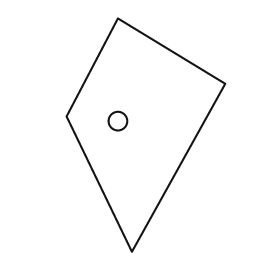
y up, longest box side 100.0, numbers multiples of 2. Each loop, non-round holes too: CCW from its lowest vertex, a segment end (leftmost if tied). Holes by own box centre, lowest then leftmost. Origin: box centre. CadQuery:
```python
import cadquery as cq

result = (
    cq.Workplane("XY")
    .moveTo(-6.0, -50.0)
    .lineTo(34.0, 22.0)
    .lineTo(-12.0, 50.0)
    .lineTo(-34.0, 8.0)
    .close()
    .moveTo(-12.0, 6.0)
    .circle(4.0)
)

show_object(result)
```